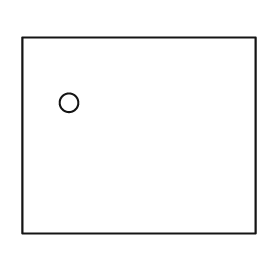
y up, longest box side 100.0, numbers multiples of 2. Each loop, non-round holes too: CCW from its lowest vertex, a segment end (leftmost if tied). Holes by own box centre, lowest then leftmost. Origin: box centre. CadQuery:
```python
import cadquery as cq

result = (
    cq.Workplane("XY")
    .moveTo(-50.0, -42.0)
    .lineTo(50.0, -42.0)
    .lineTo(50.0, 42.0)
    .lineTo(-50.0, 42.0)
    .close()
    .moveTo(-30.0, 14.0)
    .circle(4.0)
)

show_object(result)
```